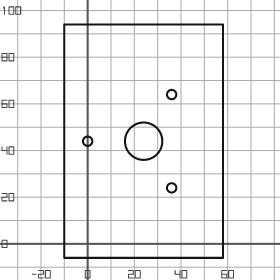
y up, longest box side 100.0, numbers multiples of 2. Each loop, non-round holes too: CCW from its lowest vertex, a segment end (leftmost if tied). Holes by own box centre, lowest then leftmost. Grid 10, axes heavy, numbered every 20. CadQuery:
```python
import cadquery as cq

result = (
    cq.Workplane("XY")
    .moveTo(-10.0, -6.0)
    .lineTo(58.0, -6.0)
    .lineTo(58.0, 94.0)
    .lineTo(-10.0, 94.0)
    .close()
    .moveTo(36.0, 24.0)
    .circle(2.0)
    .moveTo(0.0, 44.0)
    .circle(2.0)
    .moveTo(24.0, 44.0)
    .circle(8.0)
    .moveTo(36.0, 64.0)
    .circle(2.0)
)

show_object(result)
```